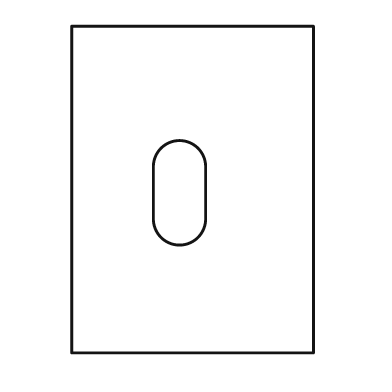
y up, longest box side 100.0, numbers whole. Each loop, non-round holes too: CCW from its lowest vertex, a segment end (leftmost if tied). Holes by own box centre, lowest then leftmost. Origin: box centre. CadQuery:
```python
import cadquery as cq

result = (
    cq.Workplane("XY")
    .moveTo(-37.0, -50.0)
    .lineTo(37.0, -50.0)
    .lineTo(37.0, 50.0)
    .lineTo(-37.0, 50.0)
    .close()
    .moveTo(-12.0, -9.0)
    .threePointArc((-4.0, -17.0), (4.0, -9.0))
    .lineTo(4.0, 7.0)
    .threePointArc((-4.0, 15.0), (-12.0, 7.0))
    .close()
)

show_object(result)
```